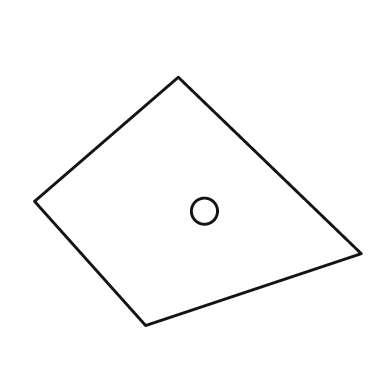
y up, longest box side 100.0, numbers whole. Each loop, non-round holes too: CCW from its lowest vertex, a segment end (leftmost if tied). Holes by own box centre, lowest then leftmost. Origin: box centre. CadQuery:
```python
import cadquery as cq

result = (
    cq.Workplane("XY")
    .moveTo(-16.0, -38.0)
    .lineTo(50.0, -16.0)
    .lineTo(-6.0, 38.0)
    .lineTo(-50.0, 0.0)
    .close()
    .moveTo(2.0, -3.0)
    .circle(4.0)
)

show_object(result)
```